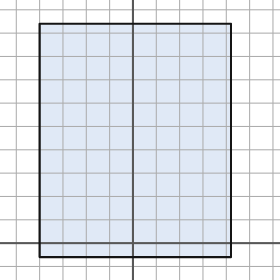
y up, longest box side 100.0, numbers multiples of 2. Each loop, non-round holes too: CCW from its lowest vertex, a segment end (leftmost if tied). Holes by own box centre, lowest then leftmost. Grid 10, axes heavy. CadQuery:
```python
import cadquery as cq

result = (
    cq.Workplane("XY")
    .moveTo(-40.0, -6.0)
    .lineTo(42.0, -6.0)
    .lineTo(42.0, 94.0)
    .lineTo(-40.0, 94.0)
    .close()
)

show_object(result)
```